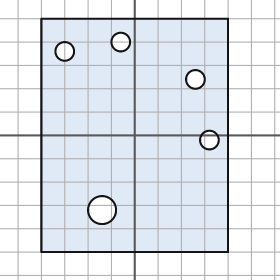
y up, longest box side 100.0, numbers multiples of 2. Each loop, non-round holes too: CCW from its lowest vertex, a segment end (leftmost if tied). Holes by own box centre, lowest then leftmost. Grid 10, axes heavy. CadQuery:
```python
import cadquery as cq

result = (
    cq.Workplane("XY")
    .moveTo(-40.0, -50.0)
    .lineTo(40.0, -50.0)
    .lineTo(40.0, 50.0)
    .lineTo(-40.0, 50.0)
    .close()
    .moveTo(-14.0, -32.0)
    .circle(6.0)
    .moveTo(32.0, -2.0)
    .circle(4.0)
    .moveTo(26.0, 24.0)
    .circle(4.0)
    .moveTo(-30.0, 36.0)
    .circle(4.0)
    .moveTo(-6.0, 40.0)
    .circle(4.0)
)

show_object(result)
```